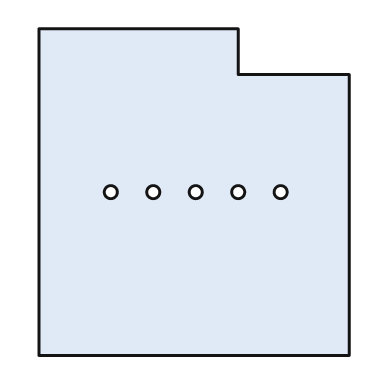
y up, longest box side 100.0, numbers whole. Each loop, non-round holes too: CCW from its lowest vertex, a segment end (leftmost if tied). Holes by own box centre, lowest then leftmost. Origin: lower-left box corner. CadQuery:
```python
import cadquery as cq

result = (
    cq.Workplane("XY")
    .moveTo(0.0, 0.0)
    .lineTo(95.0, 0.0)
    .lineTo(95.0, 86.0)
    .lineTo(61.0, 86.0)
    .lineTo(61.0, 100.0)
    .lineTo(0.0, 100.0)
    .close()
    .moveTo(22.0, 50.0)
    .circle(2.0)
    .moveTo(35.0, 50.0)
    .circle(2.0)
    .moveTo(48.0, 50.0)
    .circle(2.0)
    .moveTo(61.0, 50.0)
    .circle(2.0)
    .moveTo(74.0, 50.0)
    .circle(2.0)
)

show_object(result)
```